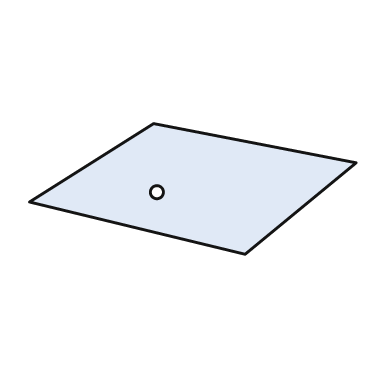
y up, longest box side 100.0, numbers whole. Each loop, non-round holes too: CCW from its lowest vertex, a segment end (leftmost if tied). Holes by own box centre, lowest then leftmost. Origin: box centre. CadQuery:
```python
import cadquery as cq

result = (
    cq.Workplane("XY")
    .moveTo(16.0, -20.0)
    .lineTo(50.0, 8.0)
    .lineTo(-12.0, 20.0)
    .lineTo(-50.0, -4.0)
    .close()
    .moveTo(-11.0, -1.0)
    .circle(2.0)
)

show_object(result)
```